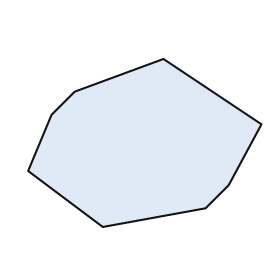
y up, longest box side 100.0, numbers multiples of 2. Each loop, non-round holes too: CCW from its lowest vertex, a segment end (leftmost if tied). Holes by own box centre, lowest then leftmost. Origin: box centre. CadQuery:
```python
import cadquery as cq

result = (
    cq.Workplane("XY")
    .moveTo(-18.0, -36.0)
    .lineTo(26.0, -28.0)
    .lineTo(36.0, -18.0)
    .lineTo(50.0, 8.0)
    .lineTo(8.0, 36.0)
    .lineTo(-30.0, 22.0)
    .lineTo(-40.0, 12.0)
    .lineTo(-50.0, -12.0)
    .close()
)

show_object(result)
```